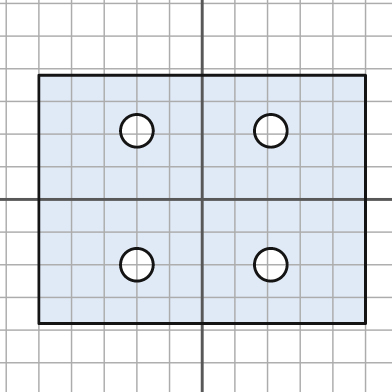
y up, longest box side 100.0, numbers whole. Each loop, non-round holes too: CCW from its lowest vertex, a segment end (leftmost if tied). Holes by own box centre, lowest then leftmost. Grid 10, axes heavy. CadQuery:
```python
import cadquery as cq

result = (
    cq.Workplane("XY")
    .moveTo(-50.0, -38.0)
    .lineTo(50.0, -38.0)
    .lineTo(50.0, 38.0)
    .lineTo(-50.0, 38.0)
    .close()
    .moveTo(-20.0, -20.0)
    .circle(5.0)
    .moveTo(21.0, -20.0)
    .circle(5.0)
    .moveTo(-20.0, 21.0)
    .circle(5.0)
    .moveTo(21.0, 21.0)
    .circle(5.0)
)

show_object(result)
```